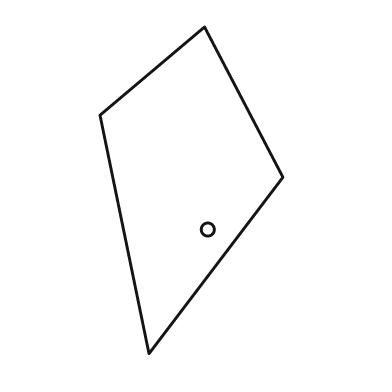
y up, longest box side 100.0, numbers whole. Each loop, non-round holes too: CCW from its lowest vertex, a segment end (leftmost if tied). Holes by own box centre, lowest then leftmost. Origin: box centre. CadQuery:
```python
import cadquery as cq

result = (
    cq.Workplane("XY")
    .moveTo(-13.0, -50.0)
    .lineTo(28.0, 4.0)
    .lineTo(4.0, 50.0)
    .lineTo(-28.0, 23.0)
    .close()
    .moveTo(5.0, -12.0)
    .circle(2.0)
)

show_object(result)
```